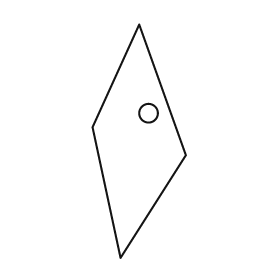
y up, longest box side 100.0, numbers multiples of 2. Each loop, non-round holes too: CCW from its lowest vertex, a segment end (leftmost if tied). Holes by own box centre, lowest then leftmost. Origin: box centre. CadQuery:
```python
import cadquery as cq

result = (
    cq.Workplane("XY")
    .moveTo(-8.0, -50.0)
    .lineTo(20.0, -6.0)
    .lineTo(0.0, 50.0)
    .lineTo(-20.0, 6.0)
    .close()
    .moveTo(4.0, 12.0)
    .circle(4.0)
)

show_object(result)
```